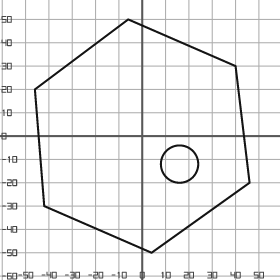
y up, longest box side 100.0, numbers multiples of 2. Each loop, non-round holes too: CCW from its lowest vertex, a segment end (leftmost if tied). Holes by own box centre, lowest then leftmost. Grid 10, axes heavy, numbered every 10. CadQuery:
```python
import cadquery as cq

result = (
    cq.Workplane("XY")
    .moveTo(4.0, -50.0)
    .lineTo(46.0, -20.0)
    .lineTo(40.0, 30.0)
    .lineTo(-6.0, 50.0)
    .lineTo(-46.0, 20.0)
    .lineTo(-42.0, -30.0)
    .close()
    .moveTo(16.0, -12.0)
    .circle(8.0)
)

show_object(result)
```